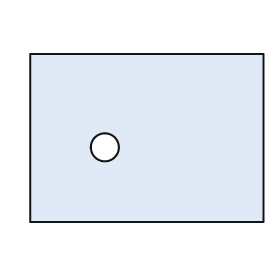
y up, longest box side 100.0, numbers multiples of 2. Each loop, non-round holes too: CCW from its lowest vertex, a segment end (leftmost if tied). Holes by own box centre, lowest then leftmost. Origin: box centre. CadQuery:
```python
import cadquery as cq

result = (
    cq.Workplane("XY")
    .moveTo(-50.0, -36.0)
    .lineTo(50.0, -36.0)
    .lineTo(50.0, 36.0)
    .lineTo(-50.0, 36.0)
    .close()
    .moveTo(-18.0, -4.0)
    .circle(6.0)
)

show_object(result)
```